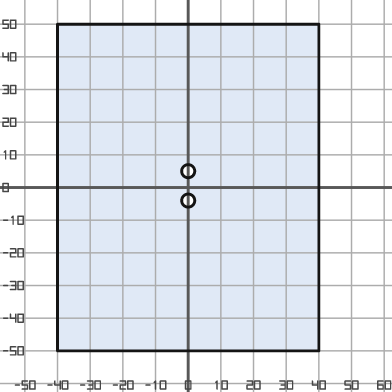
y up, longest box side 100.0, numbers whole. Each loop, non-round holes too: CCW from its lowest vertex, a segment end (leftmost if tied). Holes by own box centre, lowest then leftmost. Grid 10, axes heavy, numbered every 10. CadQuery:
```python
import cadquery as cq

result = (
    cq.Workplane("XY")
    .moveTo(-40.0, -50.0)
    .lineTo(40.0, -50.0)
    .lineTo(40.0, 50.0)
    .lineTo(-40.0, 50.0)
    .close()
    .moveTo(0.0, -4.0)
    .circle(2.0)
    .moveTo(0.0, 5.0)
    .circle(2.0)
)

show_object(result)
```